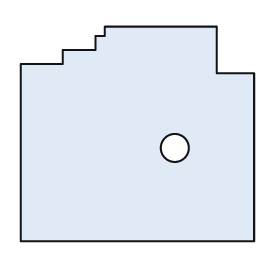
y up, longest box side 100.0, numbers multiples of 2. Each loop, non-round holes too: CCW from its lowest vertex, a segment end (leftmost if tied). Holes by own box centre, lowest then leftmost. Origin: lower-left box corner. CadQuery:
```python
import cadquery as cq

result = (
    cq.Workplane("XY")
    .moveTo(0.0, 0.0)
    .lineTo(100.0, 0.0)
    .lineTo(100.0, 72.0)
    .lineTo(84.0, 72.0)
    .lineTo(84.0, 92.0)
    .lineTo(36.0, 92.0)
    .lineTo(36.0, 88.0)
    .lineTo(32.0, 88.0)
    .lineTo(32.0, 82.0)
    .lineTo(18.0, 82.0)
    .lineTo(18.0, 76.0)
    .lineTo(0.0, 76.0)
    .close()
    .moveTo(66.0, 40.0)
    .circle(6.0)
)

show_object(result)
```